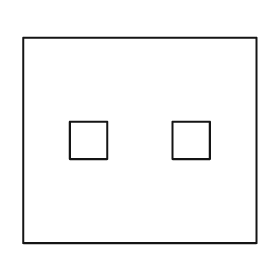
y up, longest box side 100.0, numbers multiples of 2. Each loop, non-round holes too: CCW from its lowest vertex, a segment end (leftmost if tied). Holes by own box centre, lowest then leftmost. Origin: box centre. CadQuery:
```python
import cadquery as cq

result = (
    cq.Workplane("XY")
    .moveTo(-50.0, -44.0)
    .lineTo(50.0, -44.0)
    .lineTo(50.0, 44.0)
    .lineTo(-50.0, 44.0)
    .close()
    .moveTo(-30.0, -8.0)
    .lineTo(-14.0, -8.0)
    .lineTo(-14.0, 8.0)
    .lineTo(-30.0, 8.0)
    .close()
    .moveTo(14.0, -8.0)
    .lineTo(30.0, -8.0)
    .lineTo(30.0, 8.0)
    .lineTo(14.0, 8.0)
    .close()
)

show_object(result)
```